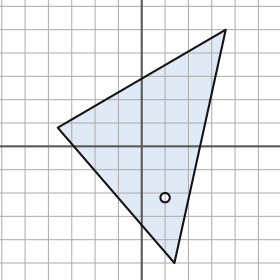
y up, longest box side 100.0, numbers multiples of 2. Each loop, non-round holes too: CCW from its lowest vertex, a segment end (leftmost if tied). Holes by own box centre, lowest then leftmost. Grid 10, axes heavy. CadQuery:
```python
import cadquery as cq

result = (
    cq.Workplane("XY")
    .moveTo(14.0, -50.0)
    .lineTo(36.0, 50.0)
    .lineTo(-36.0, 8.0)
    .close()
    .moveTo(10.0, -22.0)
    .circle(2.0)
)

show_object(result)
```